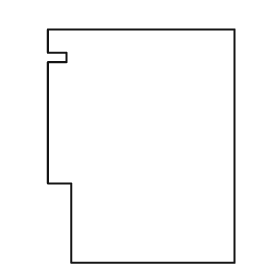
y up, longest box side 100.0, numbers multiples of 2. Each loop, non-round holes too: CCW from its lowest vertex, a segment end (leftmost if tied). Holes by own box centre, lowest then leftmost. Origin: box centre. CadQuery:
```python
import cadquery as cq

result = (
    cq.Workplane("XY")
    .moveTo(-30.0, -50.0)
    .lineTo(40.0, -50.0)
    .lineTo(40.0, 50.0)
    .lineTo(-40.0, 50.0)
    .lineTo(-40.0, 40.0)
    .lineTo(-32.0, 40.0)
    .lineTo(-32.0, 36.0)
    .lineTo(-40.0, 36.0)
    .lineTo(-40.0, -16.0)
    .lineTo(-30.0, -16.0)
    .close()
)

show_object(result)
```